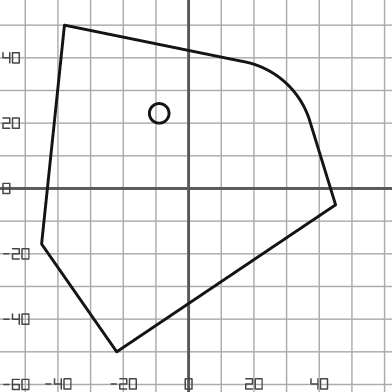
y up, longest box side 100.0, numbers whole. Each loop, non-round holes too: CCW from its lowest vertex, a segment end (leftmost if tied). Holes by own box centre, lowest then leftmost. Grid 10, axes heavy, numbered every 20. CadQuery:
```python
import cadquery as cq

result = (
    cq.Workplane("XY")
    .moveTo(-22.0, -50.0)
    .lineTo(45.0, -5.0)
    .lineTo(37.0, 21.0)
    .threePointArc((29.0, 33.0), (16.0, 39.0))
    .lineTo(-38.0, 50.0)
    .lineTo(-45.0, -17.0)
    .close()
    .moveTo(-9.0, 23.0)
    .circle(3.0)
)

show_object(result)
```